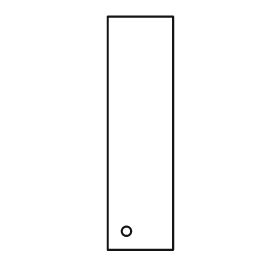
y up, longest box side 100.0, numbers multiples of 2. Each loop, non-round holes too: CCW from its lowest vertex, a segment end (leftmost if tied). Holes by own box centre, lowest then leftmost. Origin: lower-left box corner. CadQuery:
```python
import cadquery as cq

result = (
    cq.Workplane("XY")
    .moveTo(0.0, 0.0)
    .lineTo(28.0, 0.0)
    .lineTo(28.0, 100.0)
    .lineTo(0.0, 100.0)
    .close()
    .moveTo(8.0, 8.0)
    .circle(2.0)
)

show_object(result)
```